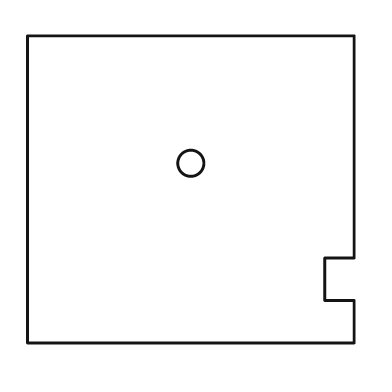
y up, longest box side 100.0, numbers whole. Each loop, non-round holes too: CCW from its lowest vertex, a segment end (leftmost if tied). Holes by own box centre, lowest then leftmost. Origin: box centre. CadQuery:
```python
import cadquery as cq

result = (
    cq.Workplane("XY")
    .moveTo(-50.0, -47.0)
    .lineTo(50.0, -47.0)
    .lineTo(50.0, -34.0)
    .lineTo(41.0, -34.0)
    .lineTo(41.0, -21.0)
    .lineTo(50.0, -21.0)
    .lineTo(50.0, 47.0)
    .lineTo(-50.0, 47.0)
    .close()
    .moveTo(0.0, 8.0)
    .circle(4.0)
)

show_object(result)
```